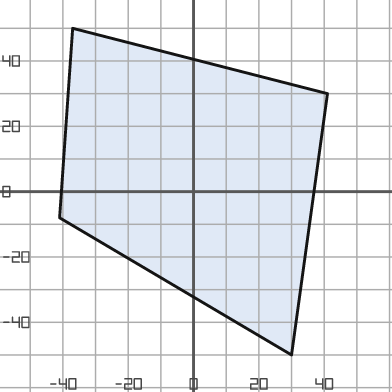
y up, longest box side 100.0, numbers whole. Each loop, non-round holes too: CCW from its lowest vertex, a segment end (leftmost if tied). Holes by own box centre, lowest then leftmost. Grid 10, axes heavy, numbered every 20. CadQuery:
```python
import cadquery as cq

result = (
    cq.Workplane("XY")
    .moveTo(30.0, -50.0)
    .lineTo(41.0, 30.0)
    .lineTo(-37.0, 50.0)
    .lineTo(-41.0, -8.0)
    .close()
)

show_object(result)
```